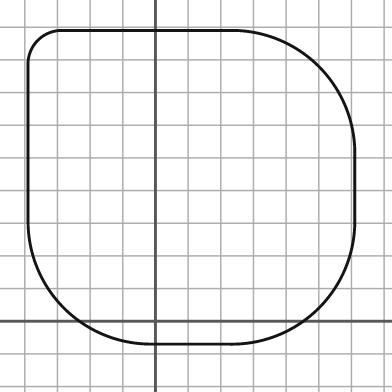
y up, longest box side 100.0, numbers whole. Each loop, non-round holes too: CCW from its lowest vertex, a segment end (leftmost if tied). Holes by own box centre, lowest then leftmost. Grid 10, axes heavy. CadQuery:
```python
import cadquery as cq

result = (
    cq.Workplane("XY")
    .moveTo(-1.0, -7.0)
    .lineTo(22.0, -7.0)
    .threePointArc((50.0, 4.0), (61.0, 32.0))
    .lineTo(61.0, 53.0)
    .threePointArc((50.0, 78.0), (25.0, 89.0))
    .lineTo(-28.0, 89.0)
    .threePointArc((-36.0, 86.0), (-39.0, 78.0))
    .lineTo(-39.0, 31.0)
    .threePointArc((-28.0, 4.0), (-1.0, -7.0))
    .close()
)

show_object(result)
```